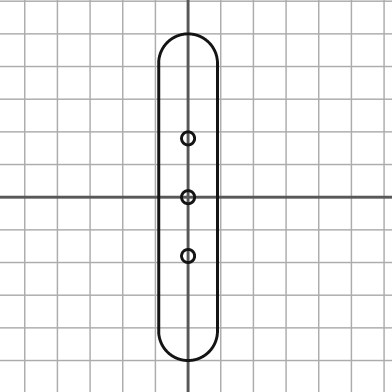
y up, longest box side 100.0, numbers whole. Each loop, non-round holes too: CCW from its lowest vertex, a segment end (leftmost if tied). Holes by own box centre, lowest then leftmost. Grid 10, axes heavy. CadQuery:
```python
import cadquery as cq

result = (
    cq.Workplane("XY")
    .moveTo(-9.0, -41.0)
    .threePointArc((0.0, -50.0), (9.0, -41.0))
    .lineTo(9.0, 41.0)
    .threePointArc((0.0, 50.0), (-9.0, 41.0))
    .close()
    .moveTo(0.0, -18.0)
    .circle(2.0)
    .moveTo(0.0, 0.0)
    .circle(2.0)
    .moveTo(0.0, 18.0)
    .circle(2.0)
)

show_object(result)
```